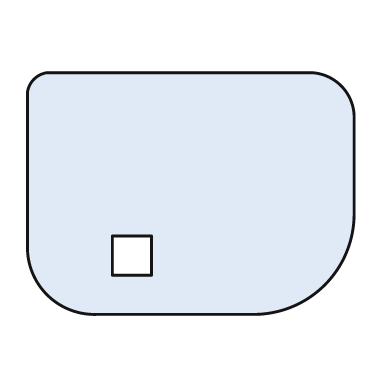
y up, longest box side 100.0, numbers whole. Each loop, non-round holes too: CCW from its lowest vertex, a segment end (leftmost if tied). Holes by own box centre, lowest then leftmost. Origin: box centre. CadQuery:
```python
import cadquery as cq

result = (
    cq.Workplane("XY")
    .moveTo(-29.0, -37.0)
    .lineTo(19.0, -37.0)
    .threePointArc((41.0, -28.0), (50.0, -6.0))
    .lineTo(50.0, 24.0)
    .threePointArc((46.0, 33.0), (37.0, 37.0))
    .lineTo(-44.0, 37.0)
    .threePointArc((-48.0, 35.0), (-50.0, 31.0))
    .lineTo(-50.0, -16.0)
    .threePointArc((-44.0, -31.0), (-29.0, -37.0))
    .close()
    .moveTo(-24.0, -25.0)
    .lineTo(-12.0, -25.0)
    .lineTo(-12.0, -13.0)
    .lineTo(-24.0, -13.0)
    .close()
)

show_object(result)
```